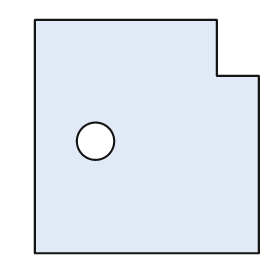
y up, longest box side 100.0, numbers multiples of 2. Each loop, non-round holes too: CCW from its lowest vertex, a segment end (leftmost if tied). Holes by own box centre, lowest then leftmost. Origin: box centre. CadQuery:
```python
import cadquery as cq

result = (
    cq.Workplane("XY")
    .moveTo(-48.0, -50.0)
    .lineTo(48.0, -50.0)
    .lineTo(48.0, 26.0)
    .lineTo(30.0, 26.0)
    .lineTo(30.0, 50.0)
    .lineTo(-48.0, 50.0)
    .close()
    .moveTo(-22.0, -2.0)
    .circle(8.0)
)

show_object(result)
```